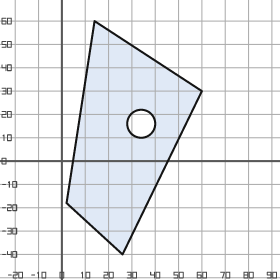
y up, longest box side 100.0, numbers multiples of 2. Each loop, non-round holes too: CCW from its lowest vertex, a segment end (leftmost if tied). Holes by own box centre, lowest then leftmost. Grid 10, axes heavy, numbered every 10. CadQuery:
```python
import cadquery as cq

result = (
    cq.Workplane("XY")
    .moveTo(26.0, -40.0)
    .lineTo(60.0, 30.0)
    .lineTo(14.0, 60.0)
    .lineTo(2.0, -18.0)
    .close()
    .moveTo(34.0, 16.0)
    .circle(6.0)
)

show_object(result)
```